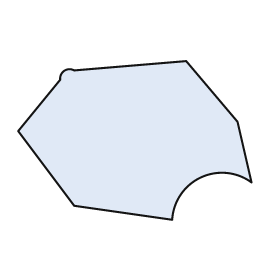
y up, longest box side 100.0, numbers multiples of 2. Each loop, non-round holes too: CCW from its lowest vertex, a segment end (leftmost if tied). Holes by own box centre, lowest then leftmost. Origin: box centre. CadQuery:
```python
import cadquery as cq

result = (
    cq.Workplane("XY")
    .moveTo(16.0, -34.0)
    .threePointArc((28.0, -16.0), (50.0, -18.0))
    .lineTo(44.0, 8.0)
    .lineTo(22.0, 34.0)
    .lineTo(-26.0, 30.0)
    .threePointArc((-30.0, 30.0), (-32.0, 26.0))
    .lineTo(-50.0, 4.0)
    .lineTo(-26.0, -28.0)
    .close()
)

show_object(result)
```